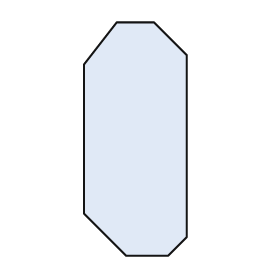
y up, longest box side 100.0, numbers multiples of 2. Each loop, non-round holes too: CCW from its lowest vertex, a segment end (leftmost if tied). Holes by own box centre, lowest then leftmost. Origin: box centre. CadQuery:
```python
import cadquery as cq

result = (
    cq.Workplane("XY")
    .moveTo(-4.0, -50.0)
    .lineTo(14.0, -50.0)
    .lineTo(22.0, -42.0)
    .lineTo(22.0, 36.0)
    .lineTo(8.0, 50.0)
    .lineTo(-8.0, 50.0)
    .lineTo(-22.0, 32.0)
    .lineTo(-22.0, -32.0)
    .close()
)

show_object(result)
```